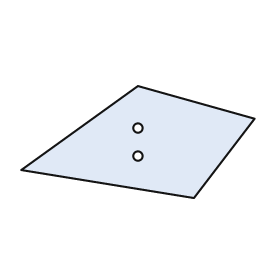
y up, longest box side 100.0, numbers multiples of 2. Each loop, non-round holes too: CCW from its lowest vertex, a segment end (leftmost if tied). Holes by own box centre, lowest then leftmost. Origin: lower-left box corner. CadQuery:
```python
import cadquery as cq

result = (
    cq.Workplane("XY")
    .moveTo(74.0, 0.0)
    .lineTo(100.0, 34.0)
    .lineTo(50.0, 48.0)
    .lineTo(0.0, 12.0)
    .close()
    .moveTo(50.0, 18.0)
    .circle(2.0)
    .moveTo(50.0, 30.0)
    .circle(2.0)
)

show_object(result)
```